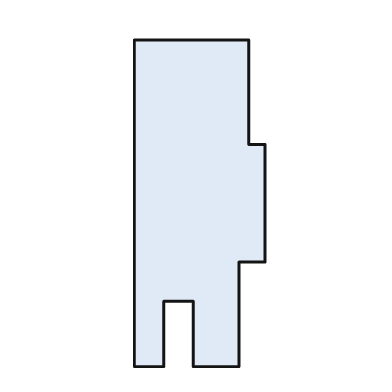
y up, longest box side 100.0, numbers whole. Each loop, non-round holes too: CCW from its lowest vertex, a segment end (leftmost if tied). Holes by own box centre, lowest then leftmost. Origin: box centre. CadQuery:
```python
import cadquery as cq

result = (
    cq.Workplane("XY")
    .moveTo(-20.0, -50.0)
    .lineTo(-11.0, -50.0)
    .lineTo(-11.0, -30.0)
    .lineTo(-2.0, -30.0)
    .lineTo(-2.0, -50.0)
    .lineTo(12.0, -50.0)
    .lineTo(12.0, -18.0)
    .lineTo(20.0, -18.0)
    .lineTo(20.0, 18.0)
    .lineTo(15.0, 18.0)
    .lineTo(15.0, 50.0)
    .lineTo(-20.0, 50.0)
    .close()
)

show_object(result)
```